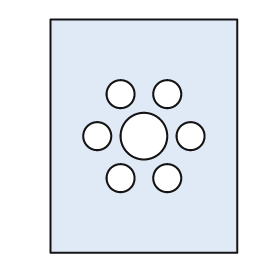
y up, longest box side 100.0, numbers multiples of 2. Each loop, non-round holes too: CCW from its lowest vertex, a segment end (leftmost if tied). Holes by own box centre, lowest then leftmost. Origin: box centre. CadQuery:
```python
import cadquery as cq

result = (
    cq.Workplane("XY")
    .moveTo(-40.0, -50.0)
    .lineTo(40.0, -50.0)
    .lineTo(40.0, 50.0)
    .lineTo(-40.0, 50.0)
    .close()
    .moveTo(-10.0, -18.0)
    .circle(6.0)
    .moveTo(10.0, -18.0)
    .circle(6.0)
    .moveTo(-20.0, 0.0)
    .circle(6.0)
    .moveTo(0.0, 0.0)
    .circle(10.0)
    .moveTo(20.0, 0.0)
    .circle(6.0)
    .moveTo(-10.0, 18.0)
    .circle(6.0)
    .moveTo(10.0, 18.0)
    .circle(6.0)
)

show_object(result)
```